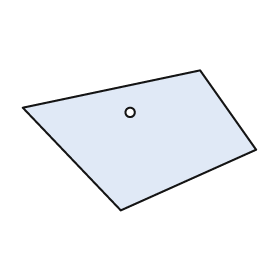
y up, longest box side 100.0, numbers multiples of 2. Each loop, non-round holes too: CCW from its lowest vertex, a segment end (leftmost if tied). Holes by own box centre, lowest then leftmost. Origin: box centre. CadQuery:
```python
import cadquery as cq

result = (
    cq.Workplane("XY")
    .moveTo(-8.0, -30.0)
    .lineTo(50.0, -4.0)
    .lineTo(26.0, 30.0)
    .lineTo(-50.0, 14.0)
    .close()
    .moveTo(-4.0, 12.0)
    .circle(2.0)
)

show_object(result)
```